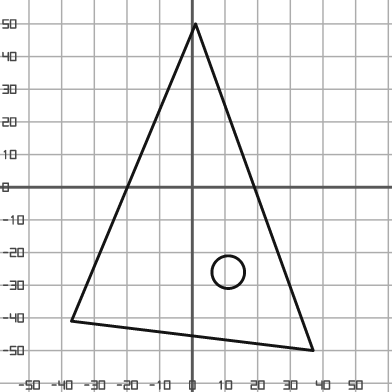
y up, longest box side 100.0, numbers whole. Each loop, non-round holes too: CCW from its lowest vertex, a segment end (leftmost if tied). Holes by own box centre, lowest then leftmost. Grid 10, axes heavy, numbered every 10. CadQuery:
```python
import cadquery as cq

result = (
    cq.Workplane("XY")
    .moveTo(37.0, -50.0)
    .lineTo(1.0, 50.0)
    .lineTo(-37.0, -41.0)
    .close()
    .moveTo(11.0, -26.0)
    .circle(5.0)
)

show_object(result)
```